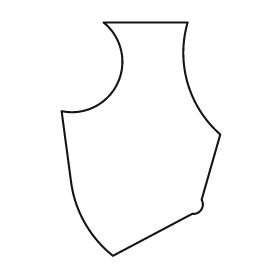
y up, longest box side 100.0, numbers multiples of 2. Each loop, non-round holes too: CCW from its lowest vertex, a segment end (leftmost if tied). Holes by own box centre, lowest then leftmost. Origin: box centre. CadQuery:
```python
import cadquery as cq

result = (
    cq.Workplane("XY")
    .moveTo(-12.0, -50.0)
    .lineTo(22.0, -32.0)
    .threePointArc((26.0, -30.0), (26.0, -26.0))
    .lineTo(34.0, 2.0)
    .threePointArc((20.0, 24.0), (20.0, 50.0))
    .lineTo(-16.0, 50.0)
    .threePointArc((-10.0, 24.0), (-34.0, 12.0))
    .lineTo(-30.0, -18.0)
    .threePointArc((-24.0, -36.0), (-12.0, -50.0))
    .close()
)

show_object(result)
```